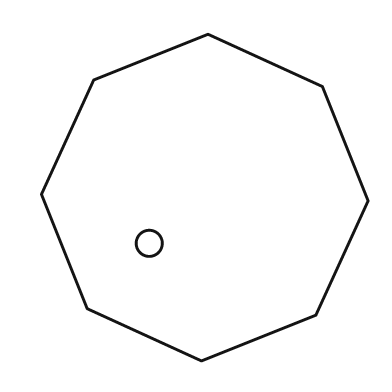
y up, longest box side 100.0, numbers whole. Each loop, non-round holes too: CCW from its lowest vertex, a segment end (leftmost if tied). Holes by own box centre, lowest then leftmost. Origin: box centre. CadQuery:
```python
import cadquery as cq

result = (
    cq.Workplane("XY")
    .moveTo(-1.0, -50.0)
    .lineTo(34.0, -36.0)
    .lineTo(50.0, -1.0)
    .lineTo(36.0, 34.0)
    .lineTo(1.0, 50.0)
    .lineTo(-34.0, 36.0)
    .lineTo(-50.0, 1.0)
    .lineTo(-36.0, -34.0)
    .close()
    .moveTo(-17.0, -14.0)
    .circle(4.0)
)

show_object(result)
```